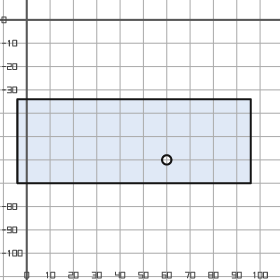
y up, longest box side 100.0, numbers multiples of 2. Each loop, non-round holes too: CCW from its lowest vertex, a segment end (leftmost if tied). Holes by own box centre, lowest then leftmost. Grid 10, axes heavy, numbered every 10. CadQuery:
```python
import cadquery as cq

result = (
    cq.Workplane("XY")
    .moveTo(-4.0, -70.0)
    .lineTo(96.0, -70.0)
    .lineTo(96.0, -34.0)
    .lineTo(-4.0, -34.0)
    .close()
    .moveTo(60.0, -60.0)
    .circle(2.0)
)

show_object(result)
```